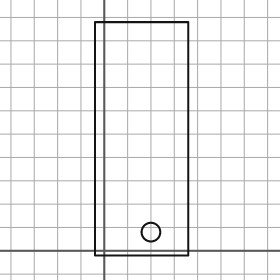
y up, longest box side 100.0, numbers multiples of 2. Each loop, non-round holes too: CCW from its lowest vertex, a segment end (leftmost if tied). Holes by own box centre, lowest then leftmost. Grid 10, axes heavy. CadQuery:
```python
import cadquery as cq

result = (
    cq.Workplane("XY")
    .moveTo(-4.0, -2.0)
    .lineTo(36.0, -2.0)
    .lineTo(36.0, 98.0)
    .lineTo(-4.0, 98.0)
    .close()
    .moveTo(20.0, 8.0)
    .circle(4.0)
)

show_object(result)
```